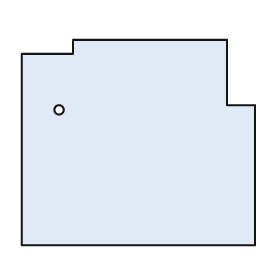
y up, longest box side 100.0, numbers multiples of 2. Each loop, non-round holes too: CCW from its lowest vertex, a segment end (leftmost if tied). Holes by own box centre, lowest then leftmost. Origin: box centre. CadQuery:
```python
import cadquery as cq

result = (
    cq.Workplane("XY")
    .moveTo(-50.0, -44.0)
    .lineTo(50.0, -44.0)
    .lineTo(50.0, 16.0)
    .lineTo(38.0, 16.0)
    .lineTo(38.0, 44.0)
    .lineTo(-28.0, 44.0)
    .lineTo(-28.0, 38.0)
    .lineTo(-50.0, 38.0)
    .close()
    .moveTo(-34.0, 14.0)
    .circle(2.0)
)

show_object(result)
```